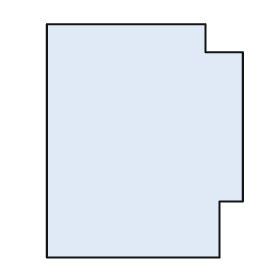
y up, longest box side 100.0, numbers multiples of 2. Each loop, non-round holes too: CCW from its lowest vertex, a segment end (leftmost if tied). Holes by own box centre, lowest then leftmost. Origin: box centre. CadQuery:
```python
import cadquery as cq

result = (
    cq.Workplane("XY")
    .moveTo(-42.0, -50.0)
    .lineTo(32.0, -50.0)
    .lineTo(32.0, -26.0)
    .lineTo(42.0, -26.0)
    .lineTo(42.0, 38.0)
    .lineTo(26.0, 38.0)
    .lineTo(26.0, 50.0)
    .lineTo(-42.0, 50.0)
    .close()
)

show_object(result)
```